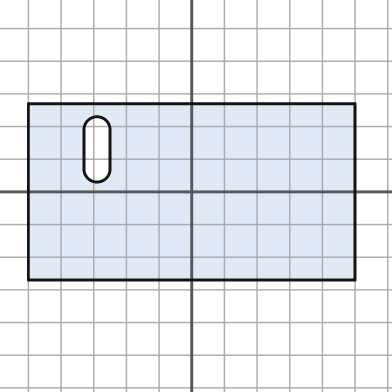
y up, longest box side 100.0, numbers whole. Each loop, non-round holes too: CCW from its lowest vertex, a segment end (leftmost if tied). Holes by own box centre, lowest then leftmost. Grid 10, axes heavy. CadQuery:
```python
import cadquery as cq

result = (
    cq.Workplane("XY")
    .moveTo(-50.0, -27.0)
    .lineTo(50.0, -27.0)
    .lineTo(50.0, 27.0)
    .lineTo(-50.0, 27.0)
    .close()
    .moveTo(-33.0, 7.0)
    .threePointArc((-29.0, 3.0), (-25.0, 7.0))
    .lineTo(-25.0, 19.0)
    .threePointArc((-29.0, 23.0), (-33.0, 19.0))
    .close()
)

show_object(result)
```